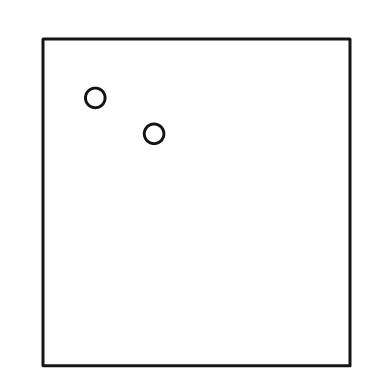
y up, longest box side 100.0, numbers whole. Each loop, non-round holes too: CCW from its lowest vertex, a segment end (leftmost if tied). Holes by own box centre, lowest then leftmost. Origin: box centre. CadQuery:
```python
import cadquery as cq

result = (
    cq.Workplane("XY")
    .moveTo(-47.0, -50.0)
    .lineTo(47.0, -50.0)
    .lineTo(47.0, 50.0)
    .lineTo(-47.0, 50.0)
    .close()
    .moveTo(-13.0, 21.0)
    .circle(3.0)
    .moveTo(-31.0, 32.0)
    .circle(3.0)
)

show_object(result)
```